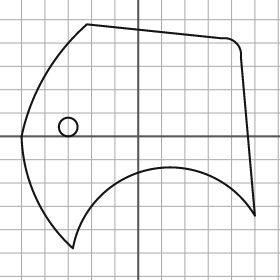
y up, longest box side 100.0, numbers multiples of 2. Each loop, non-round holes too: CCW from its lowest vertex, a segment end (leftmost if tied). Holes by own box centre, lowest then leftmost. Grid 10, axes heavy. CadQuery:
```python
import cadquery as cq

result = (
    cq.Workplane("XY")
    .moveTo(-28.0, -48.0)
    .threePointArc((6.0, -14.0), (50.0, -34.0))
    .lineTo(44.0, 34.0)
    .threePointArc((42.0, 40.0), (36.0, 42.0))
    .lineTo(-22.0, 48.0)
    .threePointArc((-40.0, 26.0), (-50.0, 0.0))
    .threePointArc((-44.0, -26.0), (-28.0, -48.0))
    .close()
    .moveTo(-30.0, 4.0)
    .circle(4.0)
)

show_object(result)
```